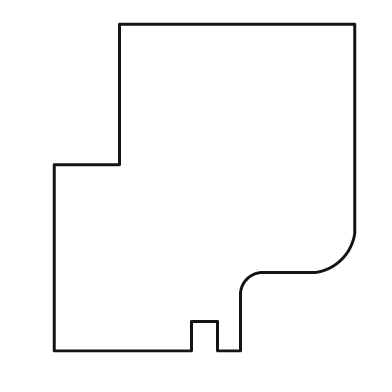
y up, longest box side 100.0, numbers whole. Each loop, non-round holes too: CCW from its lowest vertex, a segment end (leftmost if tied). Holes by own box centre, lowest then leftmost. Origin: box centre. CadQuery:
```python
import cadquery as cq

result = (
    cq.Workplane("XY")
    .moveTo(-46.0, -50.0)
    .lineTo(-4.0, -50.0)
    .lineTo(-4.0, -41.0)
    .lineTo(4.0, -41.0)
    .lineTo(4.0, -50.0)
    .lineTo(11.0, -50.0)
    .lineTo(11.0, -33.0)
    .threePointArc((13.0, -28.0), (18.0, -26.0))
    .lineTo(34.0, -26.0)
    .threePointArc((42.0, -22.0), (46.0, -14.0))
    .lineTo(46.0, 50.0)
    .lineTo(-26.0, 50.0)
    .lineTo(-26.0, 7.0)
    .lineTo(-46.0, 7.0)
    .close()
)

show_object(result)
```